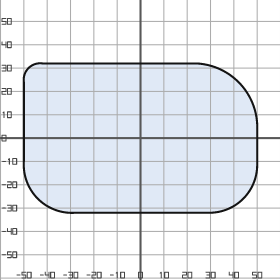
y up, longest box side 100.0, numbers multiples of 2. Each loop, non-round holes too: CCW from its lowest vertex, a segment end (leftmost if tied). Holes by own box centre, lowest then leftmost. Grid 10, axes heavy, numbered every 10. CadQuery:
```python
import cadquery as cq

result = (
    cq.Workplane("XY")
    .moveTo(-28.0, -32.0)
    .lineTo(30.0, -32.0)
    .threePointArc((44.0, -26.0), (50.0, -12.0))
    .lineTo(50.0, 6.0)
    .threePointArc((42.0, 24.0), (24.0, 32.0))
    .lineTo(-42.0, 32.0)
    .threePointArc((-48.0, 30.0), (-50.0, 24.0))
    .lineTo(-50.0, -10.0)
    .threePointArc((-44.0, -26.0), (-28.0, -32.0))
    .close()
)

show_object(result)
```